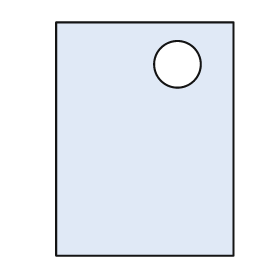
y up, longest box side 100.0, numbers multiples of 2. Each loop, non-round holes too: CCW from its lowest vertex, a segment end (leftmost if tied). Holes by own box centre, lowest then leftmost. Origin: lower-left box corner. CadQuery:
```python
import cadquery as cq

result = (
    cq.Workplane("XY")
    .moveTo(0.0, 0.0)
    .lineTo(76.0, 0.0)
    .lineTo(76.0, 100.0)
    .lineTo(0.0, 100.0)
    .close()
    .moveTo(52.0, 82.0)
    .circle(10.0)
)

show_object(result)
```